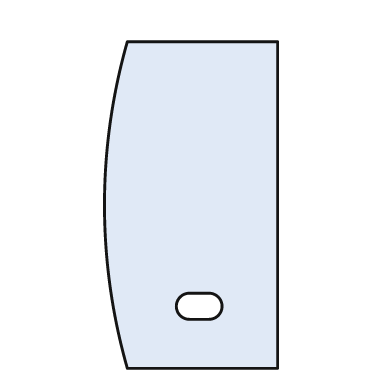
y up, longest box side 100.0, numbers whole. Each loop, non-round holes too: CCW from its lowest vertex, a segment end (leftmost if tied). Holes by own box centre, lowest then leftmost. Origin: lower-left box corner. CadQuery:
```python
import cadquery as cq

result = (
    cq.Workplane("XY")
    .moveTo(7.0, 0.0)
    .lineTo(53.0, 0.0)
    .lineTo(53.0, 100.0)
    .lineTo(7.0, 100.0)
    .threePointArc((0.0, 50.0), (7.0, 0.0))
    .close()
    .moveTo(26.0, 15.0)
    .lineTo(32.0, 15.0)
    .threePointArc((36.0, 19.0), (32.0, 23.0))
    .lineTo(26.0, 23.0)
    .threePointArc((22.0, 19.0), (26.0, 15.0))
    .close()
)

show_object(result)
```